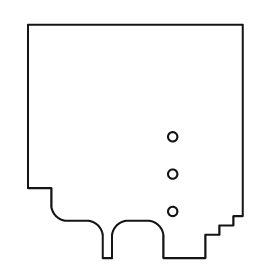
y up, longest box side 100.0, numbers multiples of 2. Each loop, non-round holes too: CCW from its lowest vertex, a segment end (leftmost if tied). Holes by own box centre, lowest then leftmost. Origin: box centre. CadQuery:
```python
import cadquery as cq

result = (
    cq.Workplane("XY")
    .moveTo(-14.0, -50.0)
    .lineTo(-10.0, -50.0)
    .lineTo(-10.0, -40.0)
    .threePointArc((-8.0, -36.0), (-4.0, -34.0))
    .lineTo(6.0, -34.0)
    .threePointArc((10.0, -36.0), (12.0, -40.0))
    .lineTo(12.0, -50.0)
    .lineTo(30.0, -50.0)
    .lineTo(30.0, -40.0)
    .lineTo(36.0, -40.0)
    .lineTo(36.0, -36.0)
    .lineTo(42.0, -36.0)
    .lineTo(42.0, -32.0)
    .lineTo(46.0, -32.0)
    .lineTo(46.0, 50.0)
    .lineTo(-46.0, 50.0)
    .lineTo(-46.0, -20.0)
    .lineTo(-36.0, -20.0)
    .lineTo(-36.0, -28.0)
    .threePointArc((-34.0, -32.0), (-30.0, -34.0))
    .lineTo(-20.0, -34.0)
    .threePointArc((-16.0, -36.0), (-14.0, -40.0))
    .close()
    .moveTo(16.0, -30.0)
    .circle(2.0)
    .moveTo(16.0, -14.0)
    .circle(2.0)
    .moveTo(16.0, 2.0)
    .circle(2.0)
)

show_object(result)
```